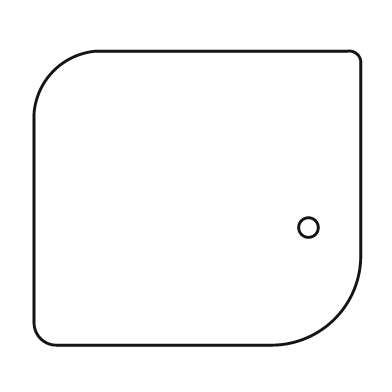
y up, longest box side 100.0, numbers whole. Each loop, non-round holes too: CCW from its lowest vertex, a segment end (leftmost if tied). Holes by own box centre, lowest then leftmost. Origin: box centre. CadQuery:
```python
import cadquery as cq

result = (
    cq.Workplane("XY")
    .moveTo(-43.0, -45.0)
    .lineTo(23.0, -45.0)
    .threePointArc((42.0, -37.0), (50.0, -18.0))
    .lineTo(50.0, 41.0)
    .threePointArc((49.0, 44.0), (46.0, 45.0))
    .lineTo(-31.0, 45.0)
    .threePointArc((-44.0, 39.0), (-50.0, 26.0))
    .lineTo(-50.0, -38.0)
    .threePointArc((-48.0, -43.0), (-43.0, -45.0))
    .close()
    .moveTo(34.0, -9.0)
    .circle(3.0)
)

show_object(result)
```